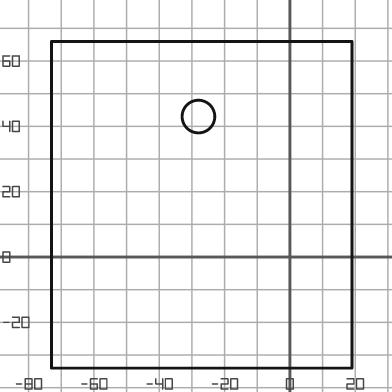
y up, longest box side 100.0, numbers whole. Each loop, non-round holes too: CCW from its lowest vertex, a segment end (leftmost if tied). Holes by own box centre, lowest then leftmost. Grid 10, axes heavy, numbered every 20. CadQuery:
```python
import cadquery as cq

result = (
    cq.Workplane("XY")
    .moveTo(-73.0, -34.0)
    .lineTo(19.0, -34.0)
    .lineTo(19.0, 66.0)
    .lineTo(-73.0, 66.0)
    .close()
    .moveTo(-28.0, 43.0)
    .circle(5.0)
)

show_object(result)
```